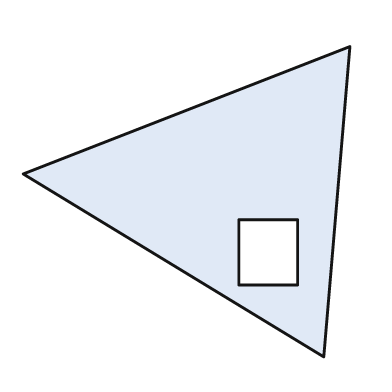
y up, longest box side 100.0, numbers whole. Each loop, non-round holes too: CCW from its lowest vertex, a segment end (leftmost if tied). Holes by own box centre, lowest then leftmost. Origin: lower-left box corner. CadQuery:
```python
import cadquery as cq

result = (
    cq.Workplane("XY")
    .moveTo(92.0, 0.0)
    .lineTo(100.0, 95.0)
    .lineTo(0.0, 56.0)
    .close()
    .moveTo(66.0, 22.0)
    .lineTo(84.0, 22.0)
    .lineTo(84.0, 42.0)
    .lineTo(66.0, 42.0)
    .close()
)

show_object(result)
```